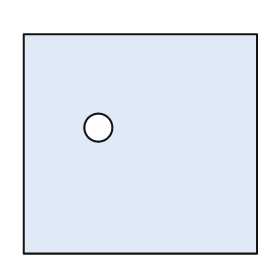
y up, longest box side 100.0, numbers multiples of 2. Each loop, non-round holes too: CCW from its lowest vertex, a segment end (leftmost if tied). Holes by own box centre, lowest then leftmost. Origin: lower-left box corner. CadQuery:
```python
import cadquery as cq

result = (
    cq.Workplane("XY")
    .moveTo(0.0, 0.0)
    .lineTo(100.0, 0.0)
    .lineTo(100.0, 94.0)
    .lineTo(0.0, 94.0)
    .close()
    .moveTo(32.0, 54.0)
    .circle(6.0)
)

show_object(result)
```